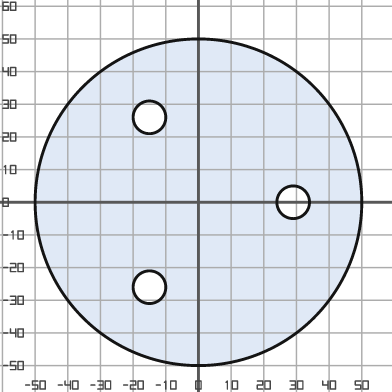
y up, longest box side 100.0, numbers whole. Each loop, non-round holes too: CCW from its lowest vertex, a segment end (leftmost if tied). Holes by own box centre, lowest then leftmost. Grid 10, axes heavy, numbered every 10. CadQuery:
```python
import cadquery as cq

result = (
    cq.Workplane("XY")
    .moveTo(0.0, 0.0)
    .circle(50.0)
    .moveTo(-15.0, -26.0)
    .circle(5.0)
    .moveTo(29.0, 0.0)
    .circle(5.0)
    .moveTo(-15.0, 26.0)
    .circle(5.0)
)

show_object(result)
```